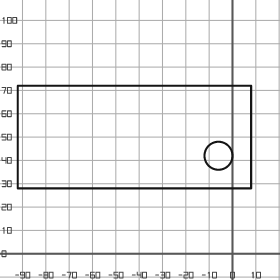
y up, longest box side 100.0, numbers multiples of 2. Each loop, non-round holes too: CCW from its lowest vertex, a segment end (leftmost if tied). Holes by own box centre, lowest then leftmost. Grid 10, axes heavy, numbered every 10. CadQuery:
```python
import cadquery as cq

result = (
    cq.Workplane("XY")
    .moveTo(-92.0, 28.0)
    .lineTo(8.0, 28.0)
    .lineTo(8.0, 72.0)
    .lineTo(-92.0, 72.0)
    .close()
    .moveTo(-6.0, 42.0)
    .circle(6.0)
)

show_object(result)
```